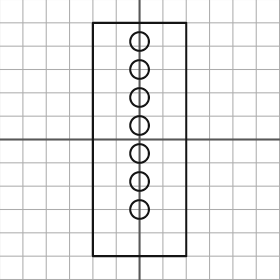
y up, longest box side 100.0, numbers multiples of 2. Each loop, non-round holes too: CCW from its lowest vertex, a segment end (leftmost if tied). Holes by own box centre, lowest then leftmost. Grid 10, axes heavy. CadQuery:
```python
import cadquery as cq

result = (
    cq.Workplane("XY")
    .moveTo(-20.0, -50.0)
    .lineTo(20.0, -50.0)
    .lineTo(20.0, 50.0)
    .lineTo(-20.0, 50.0)
    .close()
    .moveTo(0.0, -30.0)
    .circle(4.0)
    .moveTo(0.0, -18.0)
    .circle(4.0)
    .moveTo(0.0, -6.0)
    .circle(4.0)
    .moveTo(0.0, 6.0)
    .circle(4.0)
    .moveTo(0.0, 18.0)
    .circle(4.0)
    .moveTo(0.0, 30.0)
    .circle(4.0)
    .moveTo(0.0, 42.0)
    .circle(4.0)
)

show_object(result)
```